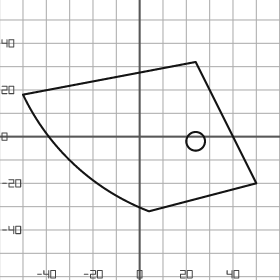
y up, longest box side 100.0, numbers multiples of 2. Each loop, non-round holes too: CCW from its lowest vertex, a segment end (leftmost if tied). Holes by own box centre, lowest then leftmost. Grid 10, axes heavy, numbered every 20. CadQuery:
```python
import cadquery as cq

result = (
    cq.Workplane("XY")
    .moveTo(4.0, -32.0)
    .lineTo(50.0, -20.0)
    .lineTo(24.0, 32.0)
    .lineTo(-50.0, 18.0)
    .threePointArc((-28.0, -12.0), (4.0, -32.0))
    .close()
    .moveTo(24.0, -2.0)
    .circle(4.0)
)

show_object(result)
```